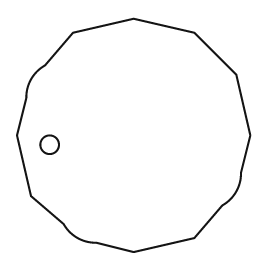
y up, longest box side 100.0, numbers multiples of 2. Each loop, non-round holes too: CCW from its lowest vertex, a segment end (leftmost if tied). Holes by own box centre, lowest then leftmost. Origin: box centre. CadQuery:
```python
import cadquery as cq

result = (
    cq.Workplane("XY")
    .moveTo(0.0, -50.0)
    .lineTo(26.0, -44.0)
    .lineTo(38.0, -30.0)
    .threePointArc((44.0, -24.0), (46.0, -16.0))
    .lineTo(50.0, 0.0)
    .lineTo(44.0, 26.0)
    .lineTo(26.0, 44.0)
    .lineTo(0.0, 50.0)
    .lineTo(-26.0, 44.0)
    .lineTo(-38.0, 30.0)
    .threePointArc((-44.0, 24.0), (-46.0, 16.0))
    .lineTo(-50.0, 0.0)
    .lineTo(-44.0, -26.0)
    .lineTo(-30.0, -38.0)
    .threePointArc((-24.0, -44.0), (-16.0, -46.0))
    .close()
    .moveTo(-36.0, -4.0)
    .circle(4.0)
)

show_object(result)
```